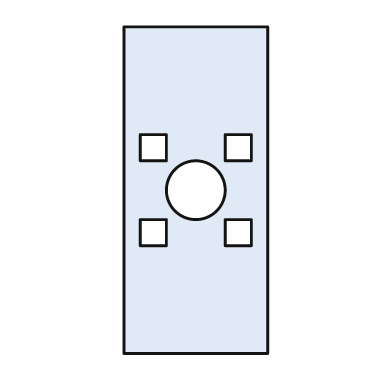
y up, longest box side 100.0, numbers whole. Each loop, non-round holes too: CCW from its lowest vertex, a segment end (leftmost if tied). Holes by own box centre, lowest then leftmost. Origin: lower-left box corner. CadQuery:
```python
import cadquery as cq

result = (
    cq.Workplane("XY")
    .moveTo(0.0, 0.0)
    .lineTo(44.0, 0.0)
    .lineTo(44.0, 100.0)
    .lineTo(0.0, 100.0)
    .close()
    .moveTo(5.0, 33.0)
    .lineTo(13.0, 33.0)
    .lineTo(13.0, 41.0)
    .lineTo(5.0, 41.0)
    .close()
    .moveTo(31.0, 33.0)
    .lineTo(39.0, 33.0)
    .lineTo(39.0, 41.0)
    .lineTo(31.0, 41.0)
    .close()
    .moveTo(22.0, 50.0)
    .circle(9.0)
    .moveTo(5.0, 59.0)
    .lineTo(13.0, 59.0)
    .lineTo(13.0, 67.0)
    .lineTo(5.0, 67.0)
    .close()
    .moveTo(31.0, 59.0)
    .lineTo(39.0, 59.0)
    .lineTo(39.0, 67.0)
    .lineTo(31.0, 67.0)
    .close()
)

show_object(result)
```